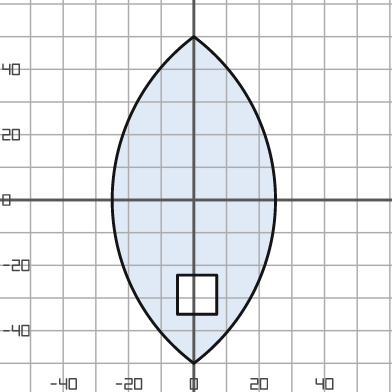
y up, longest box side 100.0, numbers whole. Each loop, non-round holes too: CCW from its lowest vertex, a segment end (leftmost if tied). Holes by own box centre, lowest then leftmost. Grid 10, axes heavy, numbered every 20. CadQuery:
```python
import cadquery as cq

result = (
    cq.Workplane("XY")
    .moveTo(0.0, -50.0)
    .threePointArc((25.0, 0.0), (0.0, 50.0))
    .threePointArc((-25.0, 0.0), (0.0, -50.0))
    .close()
    .moveTo(-5.0, -35.0)
    .lineTo(7.0, -35.0)
    .lineTo(7.0, -23.0)
    .lineTo(-5.0, -23.0)
    .close()
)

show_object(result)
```